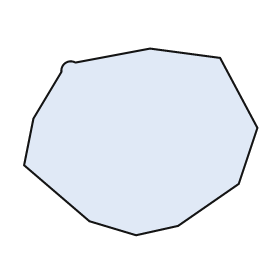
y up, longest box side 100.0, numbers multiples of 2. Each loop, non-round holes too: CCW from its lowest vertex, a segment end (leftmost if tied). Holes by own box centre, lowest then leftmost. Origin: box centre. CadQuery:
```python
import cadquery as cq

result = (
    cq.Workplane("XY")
    .moveTo(-2.0, -40.0)
    .lineTo(16.0, -36.0)
    .lineTo(42.0, -18.0)
    .lineTo(50.0, 6.0)
    .lineTo(34.0, 36.0)
    .lineTo(4.0, 40.0)
    .lineTo(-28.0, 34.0)
    .threePointArc((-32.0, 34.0), (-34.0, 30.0))
    .lineTo(-46.0, 10.0)
    .lineTo(-50.0, -10.0)
    .lineTo(-22.0, -34.0)
    .close()
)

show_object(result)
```